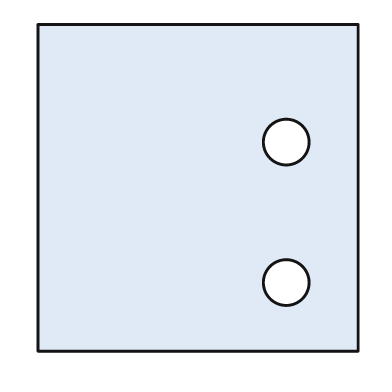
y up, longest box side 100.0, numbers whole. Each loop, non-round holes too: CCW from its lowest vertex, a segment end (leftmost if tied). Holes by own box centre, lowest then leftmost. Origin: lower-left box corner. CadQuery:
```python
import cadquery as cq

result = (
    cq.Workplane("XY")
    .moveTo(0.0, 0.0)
    .lineTo(98.0, 0.0)
    .lineTo(98.0, 100.0)
    .lineTo(0.0, 100.0)
    .close()
    .moveTo(76.0, 21.0)
    .circle(7.0)
    .moveTo(76.0, 64.0)
    .circle(7.0)
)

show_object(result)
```